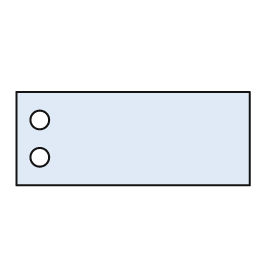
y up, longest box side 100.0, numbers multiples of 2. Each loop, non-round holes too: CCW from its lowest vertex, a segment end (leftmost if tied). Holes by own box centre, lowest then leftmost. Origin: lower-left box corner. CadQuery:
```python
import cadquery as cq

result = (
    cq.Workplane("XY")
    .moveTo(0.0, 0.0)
    .lineTo(100.0, 0.0)
    .lineTo(100.0, 40.0)
    .lineTo(0.0, 40.0)
    .close()
    .moveTo(10.0, 12.0)
    .circle(4.0)
    .moveTo(10.0, 28.0)
    .circle(4.0)
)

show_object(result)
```